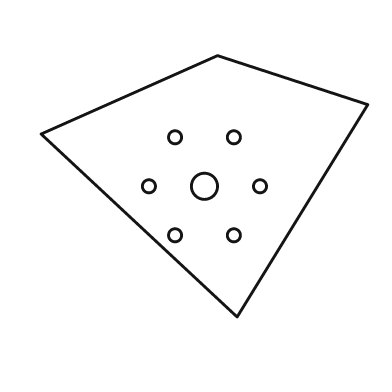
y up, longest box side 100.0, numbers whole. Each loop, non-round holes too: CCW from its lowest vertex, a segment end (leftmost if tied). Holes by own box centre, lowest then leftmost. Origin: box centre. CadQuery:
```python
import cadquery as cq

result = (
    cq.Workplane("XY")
    .moveTo(10.0, -40.0)
    .lineTo(50.0, 25.0)
    .lineTo(4.0, 40.0)
    .lineTo(-50.0, 16.0)
    .close()
    .moveTo(-9.0, -15.0)
    .circle(2.0)
    .moveTo(9.0, -15.0)
    .circle(2.0)
    .moveTo(-17.0, 0.0)
    .circle(2.0)
    .moveTo(0.0, 0.0)
    .circle(4.0)
    .moveTo(17.0, 0.0)
    .circle(2.0)
    .moveTo(-9.0, 15.0)
    .circle(2.0)
    .moveTo(9.0, 15.0)
    .circle(2.0)
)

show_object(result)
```